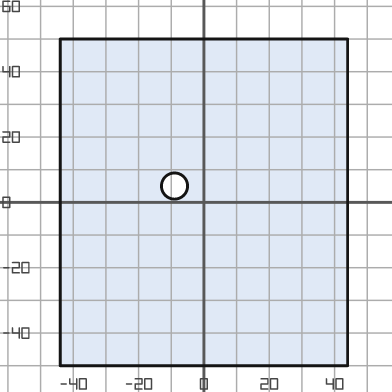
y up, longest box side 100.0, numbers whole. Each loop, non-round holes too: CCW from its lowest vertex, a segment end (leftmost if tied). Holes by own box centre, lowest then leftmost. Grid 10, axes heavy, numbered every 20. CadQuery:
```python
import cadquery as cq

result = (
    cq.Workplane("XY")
    .moveTo(-44.0, -50.0)
    .lineTo(44.0, -50.0)
    .lineTo(44.0, 50.0)
    .lineTo(-44.0, 50.0)
    .close()
    .moveTo(-9.0, 5.0)
    .circle(4.0)
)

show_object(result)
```